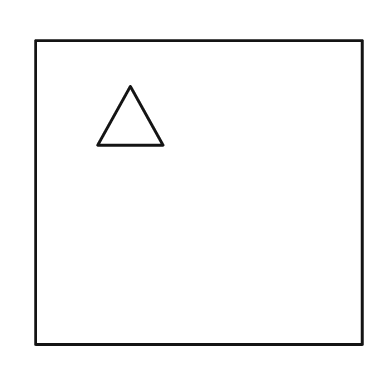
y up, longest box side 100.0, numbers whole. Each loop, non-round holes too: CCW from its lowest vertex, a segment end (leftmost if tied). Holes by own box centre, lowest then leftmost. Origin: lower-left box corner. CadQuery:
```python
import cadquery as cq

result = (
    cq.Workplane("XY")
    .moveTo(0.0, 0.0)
    .lineTo(100.0, 0.0)
    .lineTo(100.0, 93.0)
    .lineTo(0.0, 93.0)
    .close()
    .moveTo(19.0, 61.0)
    .lineTo(39.0, 61.0)
    .lineTo(29.0, 79.0)
    .close()
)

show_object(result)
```